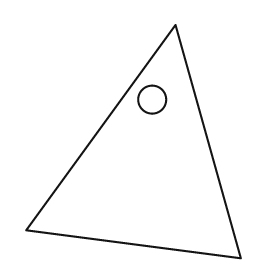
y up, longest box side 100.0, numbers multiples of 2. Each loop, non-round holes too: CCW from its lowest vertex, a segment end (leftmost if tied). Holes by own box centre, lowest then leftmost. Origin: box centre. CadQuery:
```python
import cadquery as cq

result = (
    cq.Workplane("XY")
    .moveTo(46.0, -50.0)
    .lineTo(18.0, 50.0)
    .lineTo(-46.0, -38.0)
    .close()
    .moveTo(8.0, 18.0)
    .circle(6.0)
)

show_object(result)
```